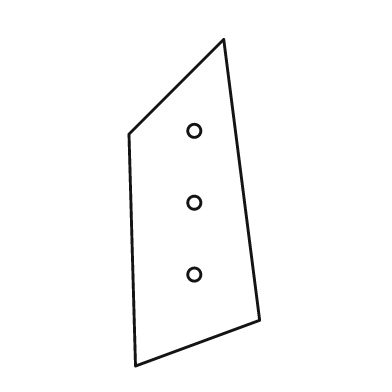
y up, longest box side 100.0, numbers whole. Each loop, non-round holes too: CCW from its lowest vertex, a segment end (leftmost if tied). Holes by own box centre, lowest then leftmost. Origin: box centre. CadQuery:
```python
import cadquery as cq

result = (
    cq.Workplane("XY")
    .moveTo(-18.0, -50.0)
    .lineTo(20.0, -36.0)
    .lineTo(9.0, 50.0)
    .lineTo(-20.0, 21.0)
    .close()
    .moveTo(0.0, -22.0)
    .circle(2.0)
    .moveTo(0.0, 0.0)
    .circle(2.0)
    .moveTo(0.0, 22.0)
    .circle(2.0)
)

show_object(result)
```